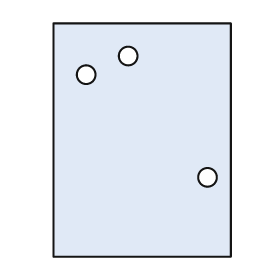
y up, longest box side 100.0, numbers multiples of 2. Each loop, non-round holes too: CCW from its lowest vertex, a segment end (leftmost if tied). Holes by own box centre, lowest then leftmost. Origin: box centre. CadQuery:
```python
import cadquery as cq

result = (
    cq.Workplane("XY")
    .moveTo(-38.0, -50.0)
    .lineTo(38.0, -50.0)
    .lineTo(38.0, 50.0)
    .lineTo(-38.0, 50.0)
    .close()
    .moveTo(28.0, -16.0)
    .circle(4.0)
    .moveTo(-24.0, 28.0)
    .circle(4.0)
    .moveTo(-6.0, 36.0)
    .circle(4.0)
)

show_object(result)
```